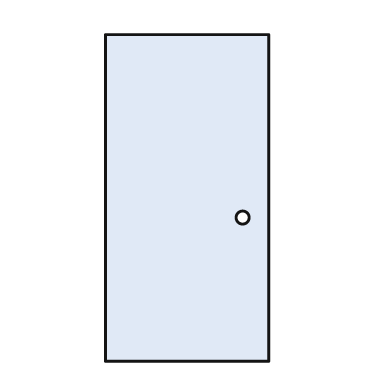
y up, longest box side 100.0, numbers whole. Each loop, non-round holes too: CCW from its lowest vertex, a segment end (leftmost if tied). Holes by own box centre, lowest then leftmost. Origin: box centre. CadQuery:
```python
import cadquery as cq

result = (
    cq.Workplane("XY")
    .moveTo(-25.0, -50.0)
    .lineTo(25.0, -50.0)
    .lineTo(25.0, 50.0)
    .lineTo(-25.0, 50.0)
    .close()
    .moveTo(17.0, -6.0)
    .circle(2.0)
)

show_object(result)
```